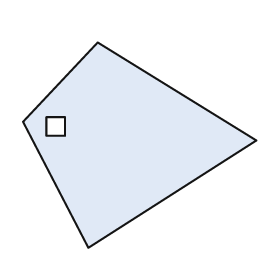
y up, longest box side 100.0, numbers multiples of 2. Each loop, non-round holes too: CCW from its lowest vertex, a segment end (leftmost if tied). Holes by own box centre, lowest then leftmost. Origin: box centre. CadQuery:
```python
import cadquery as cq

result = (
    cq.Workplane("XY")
    .moveTo(-22.0, -44.0)
    .lineTo(50.0, 2.0)
    .lineTo(-18.0, 44.0)
    .lineTo(-50.0, 10.0)
    .close()
    .moveTo(-40.0, 4.0)
    .lineTo(-32.0, 4.0)
    .lineTo(-32.0, 12.0)
    .lineTo(-40.0, 12.0)
    .close()
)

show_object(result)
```